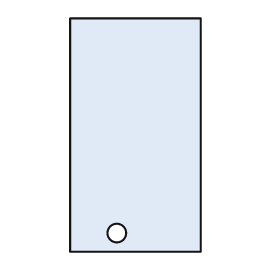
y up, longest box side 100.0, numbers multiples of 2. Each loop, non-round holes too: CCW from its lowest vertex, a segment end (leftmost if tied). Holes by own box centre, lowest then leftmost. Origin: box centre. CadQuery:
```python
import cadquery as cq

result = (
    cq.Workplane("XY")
    .moveTo(-28.0, -50.0)
    .lineTo(28.0, -50.0)
    .lineTo(28.0, 50.0)
    .lineTo(-28.0, 50.0)
    .close()
    .moveTo(-8.0, -42.0)
    .circle(4.0)
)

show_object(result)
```